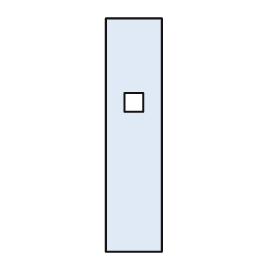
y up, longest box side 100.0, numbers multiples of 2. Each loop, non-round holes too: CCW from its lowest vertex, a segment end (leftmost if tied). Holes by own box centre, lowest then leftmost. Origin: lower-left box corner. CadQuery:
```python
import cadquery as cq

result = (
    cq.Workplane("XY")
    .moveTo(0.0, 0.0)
    .lineTo(24.0, 0.0)
    .lineTo(24.0, 100.0)
    .lineTo(0.0, 100.0)
    .close()
    .moveTo(8.0, 60.0)
    .lineTo(16.0, 60.0)
    .lineTo(16.0, 68.0)
    .lineTo(8.0, 68.0)
    .close()
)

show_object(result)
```